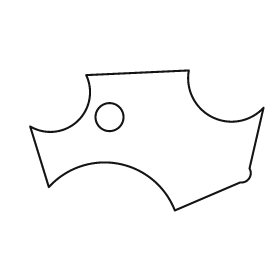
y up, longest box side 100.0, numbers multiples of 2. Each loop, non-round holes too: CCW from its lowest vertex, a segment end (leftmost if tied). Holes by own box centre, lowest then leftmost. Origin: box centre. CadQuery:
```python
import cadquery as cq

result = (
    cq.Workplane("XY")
    .moveTo(12.0, -30.0)
    .lineTo(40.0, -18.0)
    .threePointArc((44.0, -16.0), (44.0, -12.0))
    .lineTo(50.0, 14.0)
    .threePointArc((28.0, 10.0), (18.0, 30.0))
    .lineTo(-26.0, 28.0)
    .threePointArc((-30.0, 8.0), (-50.0, 6.0))
    .lineTo(-42.0, -20.0)
    .threePointArc((-12.0, -10.0), (12.0, -30.0))
    .close()
    .moveTo(-16.0, 10.0)
    .circle(6.0)
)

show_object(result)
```